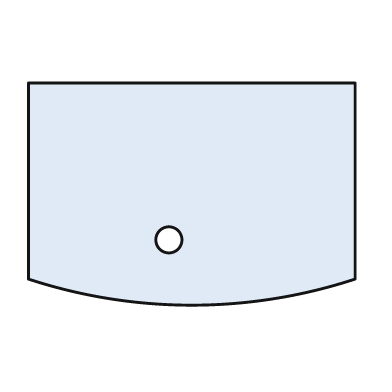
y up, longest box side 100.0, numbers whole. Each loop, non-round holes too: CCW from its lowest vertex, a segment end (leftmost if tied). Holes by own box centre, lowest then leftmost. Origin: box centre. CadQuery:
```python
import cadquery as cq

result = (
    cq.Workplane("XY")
    .moveTo(-50.0, -26.0)
    .threePointArc((0.0, -34.0), (50.0, -26.0))
    .lineTo(50.0, 34.0)
    .lineTo(-50.0, 34.0)
    .close()
    .moveTo(-7.0, -14.0)
    .circle(4.0)
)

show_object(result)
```